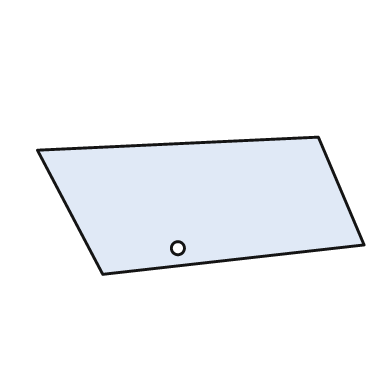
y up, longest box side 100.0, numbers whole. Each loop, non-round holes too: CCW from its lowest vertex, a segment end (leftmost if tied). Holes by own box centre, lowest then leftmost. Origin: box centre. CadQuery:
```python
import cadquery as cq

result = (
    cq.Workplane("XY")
    .moveTo(-30.0, -21.0)
    .lineTo(50.0, -12.0)
    .lineTo(36.0, 21.0)
    .lineTo(-50.0, 17.0)
    .close()
    .moveTo(-7.0, -13.0)
    .circle(2.0)
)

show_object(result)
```